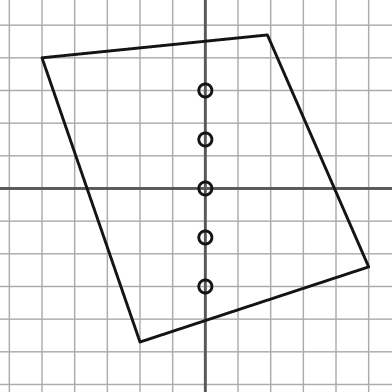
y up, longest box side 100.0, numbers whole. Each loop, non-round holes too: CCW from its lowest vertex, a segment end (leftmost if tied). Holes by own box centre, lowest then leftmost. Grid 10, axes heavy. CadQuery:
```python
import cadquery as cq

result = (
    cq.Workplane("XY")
    .moveTo(-20.0, -47.0)
    .lineTo(50.0, -24.0)
    .lineTo(19.0, 47.0)
    .lineTo(-50.0, 40.0)
    .close()
    .moveTo(0.0, -30.0)
    .circle(2.0)
    .moveTo(0.0, -15.0)
    .circle(2.0)
    .moveTo(0.0, 0.0)
    .circle(2.0)
    .moveTo(0.0, 15.0)
    .circle(2.0)
    .moveTo(0.0, 30.0)
    .circle(2.0)
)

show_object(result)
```